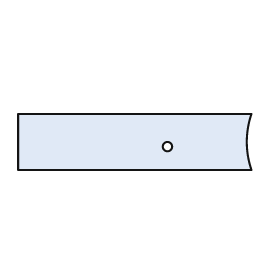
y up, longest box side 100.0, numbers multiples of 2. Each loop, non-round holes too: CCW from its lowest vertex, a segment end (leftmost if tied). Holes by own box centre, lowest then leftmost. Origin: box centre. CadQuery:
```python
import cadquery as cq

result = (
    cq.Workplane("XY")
    .moveTo(-50.0, -12.0)
    .lineTo(50.0, -12.0)
    .threePointArc((48.0, 0.0), (50.0, 12.0))
    .lineTo(-50.0, 12.0)
    .close()
    .moveTo(14.0, -2.0)
    .circle(2.0)
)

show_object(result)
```